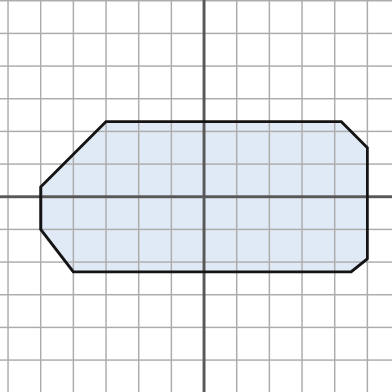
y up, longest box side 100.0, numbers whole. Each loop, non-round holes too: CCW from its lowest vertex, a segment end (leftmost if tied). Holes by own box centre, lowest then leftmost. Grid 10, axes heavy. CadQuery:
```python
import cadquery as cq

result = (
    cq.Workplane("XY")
    .moveTo(-40.0, -23.0)
    .lineTo(45.0, -23.0)
    .lineTo(50.0, -19.0)
    .lineTo(50.0, 15.0)
    .lineTo(42.0, 23.0)
    .lineTo(-30.0, 23.0)
    .lineTo(-50.0, 3.0)
    .lineTo(-50.0, -10.0)
    .close()
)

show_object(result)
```